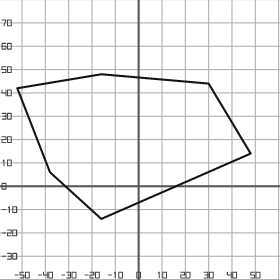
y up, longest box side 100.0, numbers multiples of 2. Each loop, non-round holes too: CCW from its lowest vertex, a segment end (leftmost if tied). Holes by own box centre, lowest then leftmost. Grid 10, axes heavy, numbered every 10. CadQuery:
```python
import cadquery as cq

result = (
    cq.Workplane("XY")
    .moveTo(-16.0, -14.0)
    .lineTo(48.0, 14.0)
    .lineTo(30.0, 44.0)
    .lineTo(-16.0, 48.0)
    .lineTo(-52.0, 42.0)
    .lineTo(-38.0, 6.0)
    .close()
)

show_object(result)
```